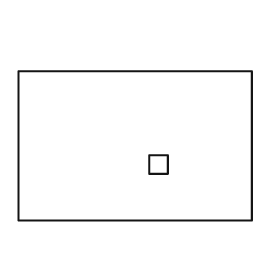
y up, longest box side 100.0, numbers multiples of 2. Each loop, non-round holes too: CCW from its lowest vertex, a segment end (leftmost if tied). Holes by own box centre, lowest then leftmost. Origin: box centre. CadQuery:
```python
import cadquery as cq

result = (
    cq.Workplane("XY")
    .moveTo(-50.0, -32.0)
    .lineTo(50.0, -32.0)
    .lineTo(50.0, 32.0)
    .lineTo(-50.0, 32.0)
    .close()
    .moveTo(6.0, -12.0)
    .lineTo(14.0, -12.0)
    .lineTo(14.0, -4.0)
    .lineTo(6.0, -4.0)
    .close()
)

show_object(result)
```